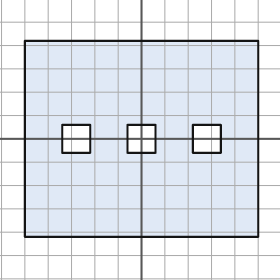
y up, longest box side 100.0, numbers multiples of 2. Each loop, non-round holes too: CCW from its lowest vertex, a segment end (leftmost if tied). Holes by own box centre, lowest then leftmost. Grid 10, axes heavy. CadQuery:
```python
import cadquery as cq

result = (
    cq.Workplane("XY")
    .moveTo(-50.0, -42.0)
    .lineTo(50.0, -42.0)
    .lineTo(50.0, 42.0)
    .lineTo(-50.0, 42.0)
    .close()
    .moveTo(-34.0, -6.0)
    .lineTo(-22.0, -6.0)
    .lineTo(-22.0, 6.0)
    .lineTo(-34.0, 6.0)
    .close()
    .moveTo(-6.0, -6.0)
    .lineTo(6.0, -6.0)
    .lineTo(6.0, 6.0)
    .lineTo(-6.0, 6.0)
    .close()
    .moveTo(22.0, -6.0)
    .lineTo(34.0, -6.0)
    .lineTo(34.0, 6.0)
    .lineTo(22.0, 6.0)
    .close()
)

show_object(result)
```